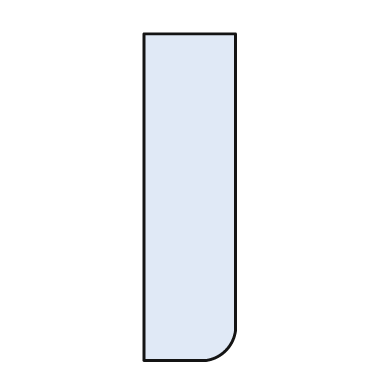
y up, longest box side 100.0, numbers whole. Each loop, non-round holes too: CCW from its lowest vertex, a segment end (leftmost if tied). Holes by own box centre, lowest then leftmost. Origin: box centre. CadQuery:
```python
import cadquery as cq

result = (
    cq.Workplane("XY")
    .moveTo(-14.0, -50.0)
    .lineTo(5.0, -50.0)
    .threePointArc((11.0, -47.0), (14.0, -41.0))
    .lineTo(14.0, 50.0)
    .lineTo(-14.0, 50.0)
    .close()
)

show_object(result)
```